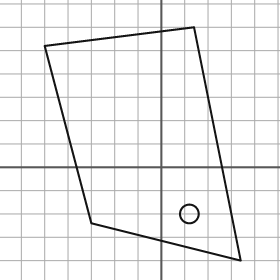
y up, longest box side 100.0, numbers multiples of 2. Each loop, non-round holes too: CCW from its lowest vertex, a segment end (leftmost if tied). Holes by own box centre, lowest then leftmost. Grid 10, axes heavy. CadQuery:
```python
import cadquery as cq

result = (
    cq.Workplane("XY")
    .moveTo(34.0, -40.0)
    .lineTo(14.0, 60.0)
    .lineTo(-50.0, 52.0)
    .lineTo(-30.0, -24.0)
    .close()
    .moveTo(12.0, -20.0)
    .circle(4.0)
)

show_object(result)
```